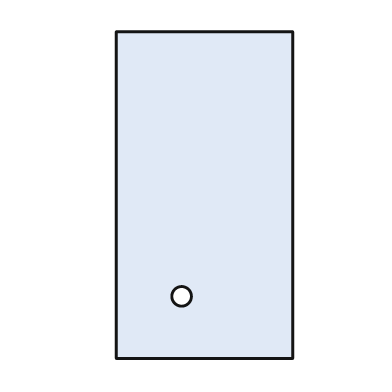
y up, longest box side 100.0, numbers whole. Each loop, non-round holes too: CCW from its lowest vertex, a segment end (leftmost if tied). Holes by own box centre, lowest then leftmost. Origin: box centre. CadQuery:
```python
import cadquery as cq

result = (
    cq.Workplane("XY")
    .moveTo(-27.0, -50.0)
    .lineTo(27.0, -50.0)
    .lineTo(27.0, 50.0)
    .lineTo(-27.0, 50.0)
    .close()
    .moveTo(-7.0, -31.0)
    .circle(3.0)
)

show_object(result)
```